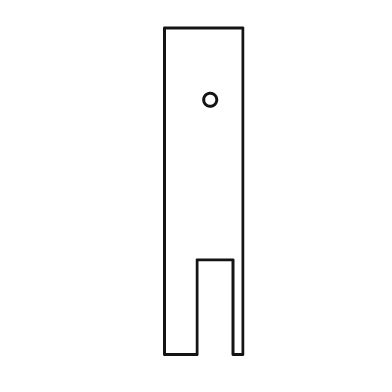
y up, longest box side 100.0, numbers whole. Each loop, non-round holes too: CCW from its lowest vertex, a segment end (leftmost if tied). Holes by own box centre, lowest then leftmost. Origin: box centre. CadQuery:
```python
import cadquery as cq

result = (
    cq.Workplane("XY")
    .moveTo(-12.0, -50.0)
    .lineTo(-2.0, -50.0)
    .lineTo(-2.0, -21.0)
    .lineTo(9.0, -21.0)
    .lineTo(9.0, -50.0)
    .lineTo(12.0, -50.0)
    .lineTo(12.0, 50.0)
    .lineTo(-12.0, 50.0)
    .close()
    .moveTo(2.0, 28.0)
    .circle(2.0)
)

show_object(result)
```